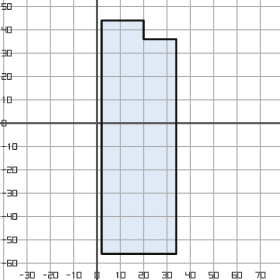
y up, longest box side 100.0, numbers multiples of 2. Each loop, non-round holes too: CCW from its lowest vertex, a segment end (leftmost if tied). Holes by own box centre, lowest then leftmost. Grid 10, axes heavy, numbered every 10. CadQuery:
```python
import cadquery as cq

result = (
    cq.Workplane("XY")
    .moveTo(2.0, -56.0)
    .lineTo(34.0, -56.0)
    .lineTo(34.0, 36.0)
    .lineTo(20.0, 36.0)
    .lineTo(20.0, 44.0)
    .lineTo(2.0, 44.0)
    .close()
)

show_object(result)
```